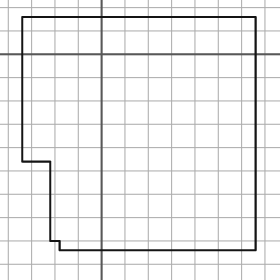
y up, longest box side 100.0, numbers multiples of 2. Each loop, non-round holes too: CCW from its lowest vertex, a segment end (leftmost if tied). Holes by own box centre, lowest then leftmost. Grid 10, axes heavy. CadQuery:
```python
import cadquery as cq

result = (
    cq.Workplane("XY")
    .moveTo(-18.0, -84.0)
    .lineTo(66.0, -84.0)
    .lineTo(66.0, 16.0)
    .lineTo(-34.0, 16.0)
    .lineTo(-34.0, -46.0)
    .lineTo(-22.0, -46.0)
    .lineTo(-22.0, -80.0)
    .lineTo(-18.0, -80.0)
    .close()
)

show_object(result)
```